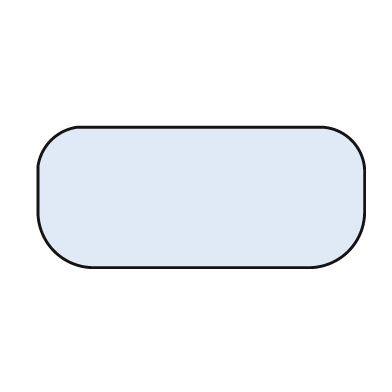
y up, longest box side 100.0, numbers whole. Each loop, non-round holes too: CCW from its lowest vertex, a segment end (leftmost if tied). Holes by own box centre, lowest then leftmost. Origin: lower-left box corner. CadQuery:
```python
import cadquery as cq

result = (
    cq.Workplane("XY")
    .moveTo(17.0, 0.0)
    .lineTo(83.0, 0.0)
    .threePointArc((95.0, 5.0), (100.0, 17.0))
    .lineTo(100.0, 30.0)
    .threePointArc((96.0, 39.0), (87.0, 43.0))
    .lineTo(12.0, 43.0)
    .threePointArc((4.0, 39.0), (0.0, 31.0))
    .lineTo(0.0, 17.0)
    .threePointArc((5.0, 5.0), (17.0, 0.0))
    .close()
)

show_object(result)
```